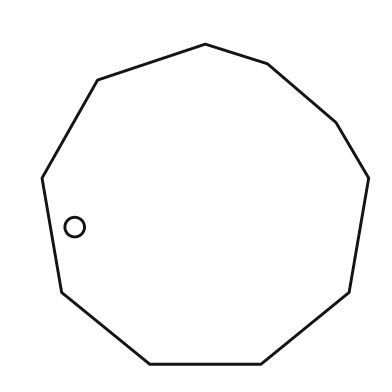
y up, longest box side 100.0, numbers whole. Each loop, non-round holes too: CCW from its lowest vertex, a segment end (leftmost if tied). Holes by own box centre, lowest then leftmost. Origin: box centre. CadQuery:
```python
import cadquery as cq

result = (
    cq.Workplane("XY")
    .moveTo(-17.0, -49.0)
    .lineTo(17.0, -49.0)
    .lineTo(44.0, -27.0)
    .lineTo(50.0, 8.0)
    .lineTo(40.0, 25.0)
    .lineTo(19.0, 43.0)
    .lineTo(0.0, 49.0)
    .lineTo(-33.0, 38.0)
    .lineTo(-50.0, 8.0)
    .lineTo(-44.0, -27.0)
    .close()
    .moveTo(-40.0, -7.0)
    .circle(3.0)
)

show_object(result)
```